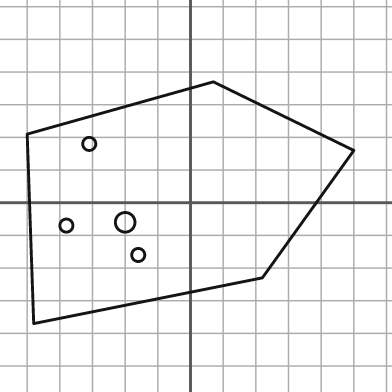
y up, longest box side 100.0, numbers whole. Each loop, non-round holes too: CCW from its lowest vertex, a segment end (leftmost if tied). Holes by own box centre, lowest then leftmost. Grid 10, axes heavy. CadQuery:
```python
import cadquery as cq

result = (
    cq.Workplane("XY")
    .moveTo(-48.0, -37.0)
    .lineTo(22.0, -23.0)
    .lineTo(50.0, 16.0)
    .lineTo(7.0, 37.0)
    .lineTo(-50.0, 21.0)
    .close()
    .moveTo(-16.0, -16.0)
    .circle(2.0)
    .moveTo(-38.0, -7.0)
    .circle(2.0)
    .moveTo(-20.0, -6.0)
    .circle(3.0)
    .moveTo(-31.0, 18.0)
    .circle(2.0)
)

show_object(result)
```